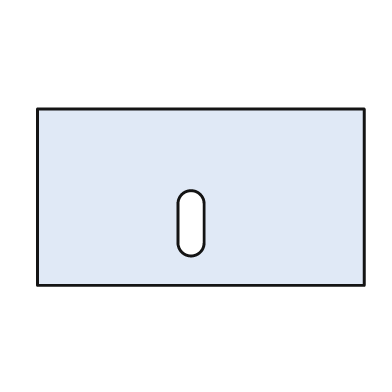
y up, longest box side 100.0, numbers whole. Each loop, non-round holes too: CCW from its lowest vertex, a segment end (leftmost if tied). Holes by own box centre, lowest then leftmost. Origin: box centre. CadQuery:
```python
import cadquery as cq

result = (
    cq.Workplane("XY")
    .moveTo(-50.0, -27.0)
    .lineTo(50.0, -27.0)
    .lineTo(50.0, 27.0)
    .lineTo(-50.0, 27.0)
    .close()
    .moveTo(-7.0, -14.0)
    .threePointArc((-3.0, -18.0), (1.0, -14.0))
    .lineTo(1.0, -2.0)
    .threePointArc((-3.0, 2.0), (-7.0, -2.0))
    .close()
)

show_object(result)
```